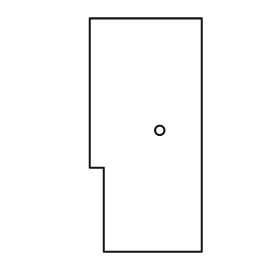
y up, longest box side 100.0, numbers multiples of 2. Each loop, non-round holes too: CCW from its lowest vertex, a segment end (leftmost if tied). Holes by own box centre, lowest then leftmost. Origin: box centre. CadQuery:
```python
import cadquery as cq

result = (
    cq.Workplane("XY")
    .moveTo(-18.0, -50.0)
    .lineTo(24.0, -50.0)
    .lineTo(24.0, 50.0)
    .lineTo(-24.0, 50.0)
    .lineTo(-24.0, -14.0)
    .lineTo(-18.0, -14.0)
    .close()
    .moveTo(6.0, 2.0)
    .circle(2.0)
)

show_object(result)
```